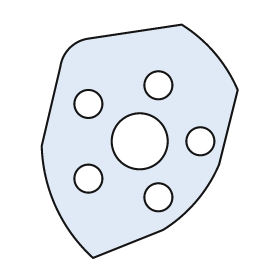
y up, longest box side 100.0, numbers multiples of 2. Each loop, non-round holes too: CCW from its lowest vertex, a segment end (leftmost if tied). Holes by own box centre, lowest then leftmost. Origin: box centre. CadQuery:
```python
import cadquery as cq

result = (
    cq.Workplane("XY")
    .moveTo(-20.0, -50.0)
    .lineTo(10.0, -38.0)
    .threePointArc((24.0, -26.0), (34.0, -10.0))
    .lineTo(42.0, 22.0)
    .threePointArc((32.0, 38.0), (18.0, 50.0))
    .lineTo(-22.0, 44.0)
    .threePointArc((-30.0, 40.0), (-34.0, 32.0))
    .lineTo(-42.0, -2.0)
    .threePointArc((-36.0, -28.0), (-20.0, -50.0))
    .close()
    .moveTo(8.0, -24.0)
    .circle(6.0)
    .moveTo(-22.0, -16.0)
    .circle(6.0)
    .moveTo(0.0, 0.0)
    .circle(12.0)
    .moveTo(26.0, 0.0)
    .circle(6.0)
    .moveTo(-22.0, 16.0)
    .circle(6.0)
    .moveTo(8.0, 24.0)
    .circle(6.0)
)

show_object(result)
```